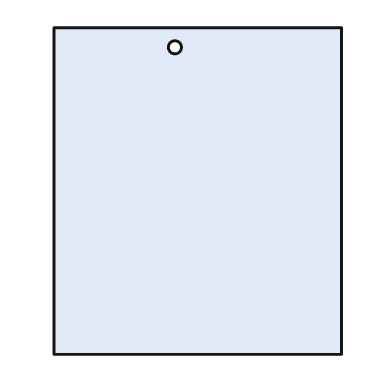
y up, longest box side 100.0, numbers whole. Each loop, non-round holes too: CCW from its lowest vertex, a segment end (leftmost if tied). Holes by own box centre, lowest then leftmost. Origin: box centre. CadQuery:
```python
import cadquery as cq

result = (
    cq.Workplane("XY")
    .moveTo(-44.0, -50.0)
    .lineTo(44.0, -50.0)
    .lineTo(44.0, 50.0)
    .lineTo(-44.0, 50.0)
    .close()
    .moveTo(-7.0, 44.0)
    .circle(2.0)
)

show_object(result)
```